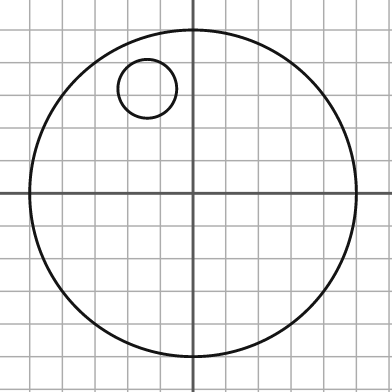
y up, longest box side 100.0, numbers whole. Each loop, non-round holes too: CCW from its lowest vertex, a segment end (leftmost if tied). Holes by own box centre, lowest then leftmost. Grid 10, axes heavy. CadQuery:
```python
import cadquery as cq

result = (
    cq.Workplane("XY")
    .moveTo(0.0, 0.0)
    .circle(50.0)
    .moveTo(-14.0, 32.0)
    .circle(9.0)
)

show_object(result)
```